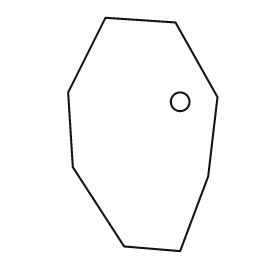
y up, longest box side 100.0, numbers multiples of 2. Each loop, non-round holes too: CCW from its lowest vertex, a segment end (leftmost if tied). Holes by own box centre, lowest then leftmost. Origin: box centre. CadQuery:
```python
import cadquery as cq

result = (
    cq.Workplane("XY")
    .moveTo(16.0, -50.0)
    .lineTo(28.0, -18.0)
    .lineTo(32.0, 16.0)
    .lineTo(14.0, 48.0)
    .lineTo(-16.0, 50.0)
    .lineTo(-32.0, 18.0)
    .lineTo(-30.0, -14.0)
    .lineTo(-8.0, -48.0)
    .close()
    .moveTo(16.0, 14.0)
    .circle(4.0)
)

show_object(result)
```